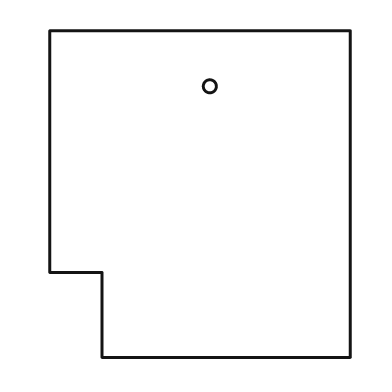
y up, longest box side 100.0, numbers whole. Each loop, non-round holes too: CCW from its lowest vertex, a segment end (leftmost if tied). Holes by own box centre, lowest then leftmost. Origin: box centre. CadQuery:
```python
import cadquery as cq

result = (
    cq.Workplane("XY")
    .moveTo(-30.0, -50.0)
    .lineTo(46.0, -50.0)
    .lineTo(46.0, 50.0)
    .lineTo(-46.0, 50.0)
    .lineTo(-46.0, -24.0)
    .lineTo(-30.0, -24.0)
    .close()
    .moveTo(3.0, 33.0)
    .circle(2.0)
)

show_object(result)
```